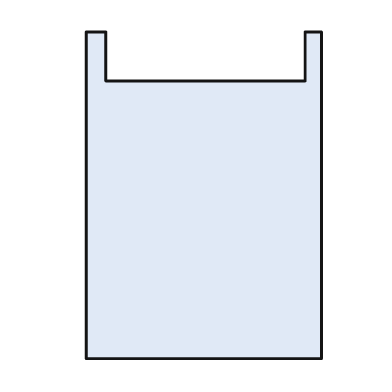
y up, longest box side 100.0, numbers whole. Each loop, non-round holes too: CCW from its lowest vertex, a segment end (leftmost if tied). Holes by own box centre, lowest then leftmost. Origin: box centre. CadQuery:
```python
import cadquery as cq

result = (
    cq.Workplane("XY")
    .moveTo(-36.0, -50.0)
    .lineTo(36.0, -50.0)
    .lineTo(36.0, 50.0)
    .lineTo(31.0, 50.0)
    .lineTo(31.0, 35.0)
    .lineTo(-30.0, 35.0)
    .lineTo(-30.0, 50.0)
    .lineTo(-36.0, 50.0)
    .close()
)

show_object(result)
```